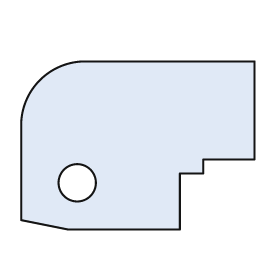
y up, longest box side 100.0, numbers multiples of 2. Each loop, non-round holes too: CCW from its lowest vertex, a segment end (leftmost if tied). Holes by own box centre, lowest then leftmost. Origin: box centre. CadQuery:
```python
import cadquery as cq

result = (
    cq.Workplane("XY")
    .moveTo(-30.0, -36.0)
    .lineTo(18.0, -36.0)
    .lineTo(18.0, -12.0)
    .lineTo(28.0, -12.0)
    .lineTo(28.0, -6.0)
    .lineTo(50.0, -6.0)
    .lineTo(50.0, 36.0)
    .lineTo(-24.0, 36.0)
    .threePointArc((-42.0, 28.0), (-50.0, 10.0))
    .lineTo(-50.0, -32.0)
    .close()
    .moveTo(-26.0, -16.0)
    .circle(8.0)
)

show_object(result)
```